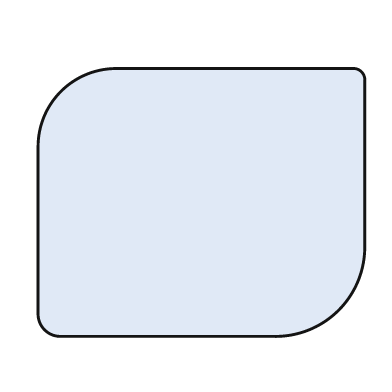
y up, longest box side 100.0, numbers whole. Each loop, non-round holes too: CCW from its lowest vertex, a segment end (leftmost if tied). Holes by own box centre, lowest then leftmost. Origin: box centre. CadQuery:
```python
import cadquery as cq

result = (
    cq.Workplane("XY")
    .moveTo(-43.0, -41.0)
    .lineTo(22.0, -41.0)
    .threePointArc((42.0, -33.0), (50.0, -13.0))
    .lineTo(50.0, 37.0)
    .threePointArc((49.0, 40.0), (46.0, 41.0))
    .lineTo(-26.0, 41.0)
    .threePointArc((-43.0, 34.0), (-50.0, 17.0))
    .lineTo(-50.0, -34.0)
    .threePointArc((-48.0, -39.0), (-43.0, -41.0))
    .close()
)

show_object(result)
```